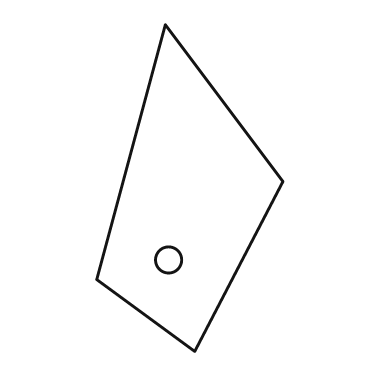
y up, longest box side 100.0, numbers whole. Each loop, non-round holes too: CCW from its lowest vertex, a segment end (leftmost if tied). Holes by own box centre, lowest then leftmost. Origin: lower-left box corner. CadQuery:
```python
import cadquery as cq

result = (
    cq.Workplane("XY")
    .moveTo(30.0, 0.0)
    .lineTo(57.0, 52.0)
    .lineTo(21.0, 100.0)
    .lineTo(0.0, 22.0)
    .close()
    .moveTo(22.0, 28.0)
    .circle(4.0)
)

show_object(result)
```